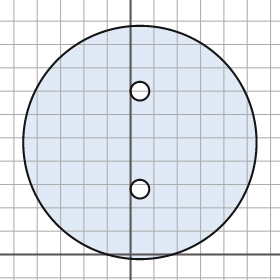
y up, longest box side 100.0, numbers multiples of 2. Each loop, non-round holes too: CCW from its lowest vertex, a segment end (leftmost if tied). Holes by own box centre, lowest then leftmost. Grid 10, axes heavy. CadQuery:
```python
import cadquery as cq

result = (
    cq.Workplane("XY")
    .moveTo(4.0, 48.0)
    .circle(50.0)
    .moveTo(4.0, 28.0)
    .circle(4.0)
    .moveTo(4.0, 70.0)
    .circle(4.0)
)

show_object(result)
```